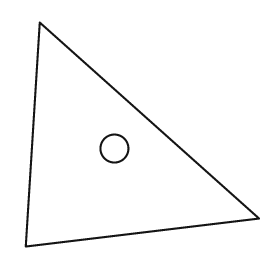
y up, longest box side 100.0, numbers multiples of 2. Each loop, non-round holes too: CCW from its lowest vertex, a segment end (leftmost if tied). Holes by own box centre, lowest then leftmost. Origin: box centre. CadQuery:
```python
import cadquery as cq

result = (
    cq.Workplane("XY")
    .moveTo(-50.0, -48.0)
    .lineTo(50.0, -36.0)
    .lineTo(-44.0, 48.0)
    .close()
    .moveTo(-12.0, -6.0)
    .circle(6.0)
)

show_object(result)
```